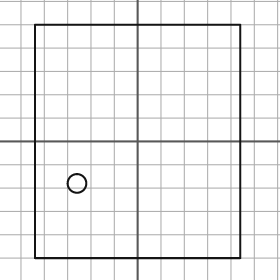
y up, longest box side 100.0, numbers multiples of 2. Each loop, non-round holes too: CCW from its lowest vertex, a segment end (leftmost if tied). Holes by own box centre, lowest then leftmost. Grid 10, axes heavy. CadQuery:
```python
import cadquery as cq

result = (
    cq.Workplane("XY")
    .moveTo(-44.0, -50.0)
    .lineTo(44.0, -50.0)
    .lineTo(44.0, 50.0)
    .lineTo(-44.0, 50.0)
    .close()
    .moveTo(-26.0, -18.0)
    .circle(4.0)
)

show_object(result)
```